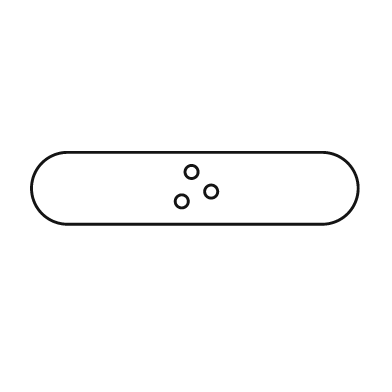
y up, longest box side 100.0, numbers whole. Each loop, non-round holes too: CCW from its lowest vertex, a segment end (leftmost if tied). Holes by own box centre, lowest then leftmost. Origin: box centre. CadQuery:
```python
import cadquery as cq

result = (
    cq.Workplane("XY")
    .moveTo(-39.0, -11.0)
    .lineTo(39.0, -11.0)
    .threePointArc((50.0, 0.0), (39.0, 11.0))
    .lineTo(-39.0, 11.0)
    .threePointArc((-50.0, 0.0), (-39.0, -11.0))
    .close()
    .moveTo(-4.0, -4.0)
    .circle(2.0)
    .moveTo(5.0, -1.0)
    .circle(2.0)
    .moveTo(-1.0, 5.0)
    .circle(2.0)
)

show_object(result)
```